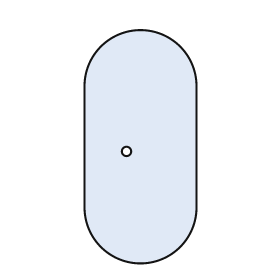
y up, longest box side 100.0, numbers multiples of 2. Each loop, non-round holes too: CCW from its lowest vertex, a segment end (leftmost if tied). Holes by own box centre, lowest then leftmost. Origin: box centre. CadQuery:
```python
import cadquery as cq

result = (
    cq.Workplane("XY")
    .moveTo(-24.0, -26.0)
    .threePointArc((0.0, -50.0), (24.0, -26.0))
    .lineTo(24.0, 26.0)
    .threePointArc((0.0, 50.0), (-24.0, 26.0))
    .close()
    .moveTo(-6.0, -2.0)
    .circle(2.0)
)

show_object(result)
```